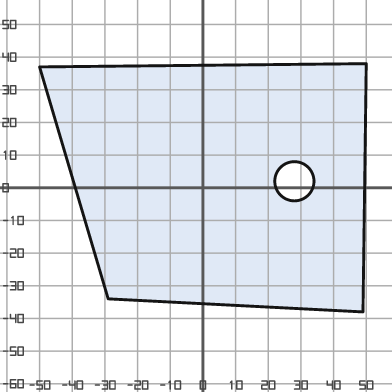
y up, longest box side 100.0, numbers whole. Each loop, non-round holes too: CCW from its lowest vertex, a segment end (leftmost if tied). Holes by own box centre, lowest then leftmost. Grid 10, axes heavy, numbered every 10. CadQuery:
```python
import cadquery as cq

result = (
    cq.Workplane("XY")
    .moveTo(49.0, -38.0)
    .lineTo(50.0, 38.0)
    .lineTo(-50.0, 37.0)
    .lineTo(-29.0, -34.0)
    .close()
    .moveTo(28.0, 2.0)
    .circle(6.0)
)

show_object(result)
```